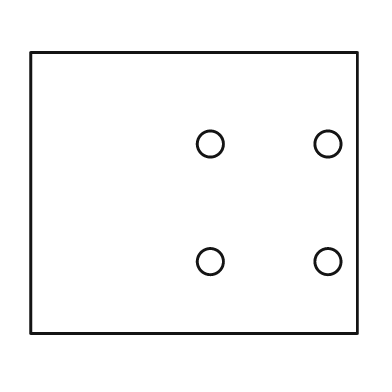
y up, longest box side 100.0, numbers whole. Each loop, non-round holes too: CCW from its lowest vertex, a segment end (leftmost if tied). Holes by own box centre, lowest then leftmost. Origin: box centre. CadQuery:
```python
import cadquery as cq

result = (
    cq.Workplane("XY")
    .moveTo(-50.0, -43.0)
    .lineTo(50.0, -43.0)
    .lineTo(50.0, 43.0)
    .lineTo(-50.0, 43.0)
    .close()
    .moveTo(5.0, -21.0)
    .circle(4.0)
    .moveTo(41.0, -21.0)
    .circle(4.0)
    .moveTo(5.0, 15.0)
    .circle(4.0)
    .moveTo(41.0, 15.0)
    .circle(4.0)
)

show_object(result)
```